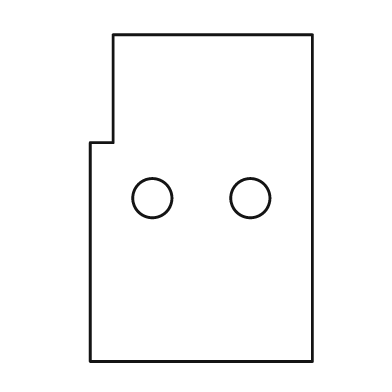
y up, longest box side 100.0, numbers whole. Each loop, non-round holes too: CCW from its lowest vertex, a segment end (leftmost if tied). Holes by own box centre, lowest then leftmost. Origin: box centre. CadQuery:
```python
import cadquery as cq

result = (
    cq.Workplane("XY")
    .moveTo(-34.0, -50.0)
    .lineTo(34.0, -50.0)
    .lineTo(34.0, 50.0)
    .lineTo(-27.0, 50.0)
    .lineTo(-27.0, 17.0)
    .lineTo(-34.0, 17.0)
    .close()
    .moveTo(-15.0, 0.0)
    .circle(6.0)
    .moveTo(15.0, 0.0)
    .circle(6.0)
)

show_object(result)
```